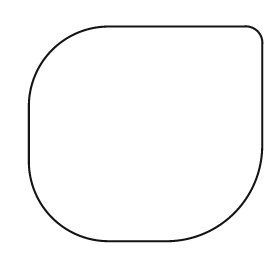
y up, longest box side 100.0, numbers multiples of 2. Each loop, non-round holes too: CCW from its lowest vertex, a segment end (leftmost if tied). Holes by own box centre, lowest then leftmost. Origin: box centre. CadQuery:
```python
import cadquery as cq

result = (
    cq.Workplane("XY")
    .moveTo(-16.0, -46.0)
    .lineTo(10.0, -46.0)
    .threePointArc((38.0, -34.0), (50.0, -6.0))
    .lineTo(50.0, 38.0)
    .threePointArc((48.0, 44.0), (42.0, 46.0))
    .lineTo(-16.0, 46.0)
    .threePointArc((-40.0, 36.0), (-50.0, 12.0))
    .lineTo(-50.0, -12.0)
    .threePointArc((-40.0, -36.0), (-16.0, -46.0))
    .close()
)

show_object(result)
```